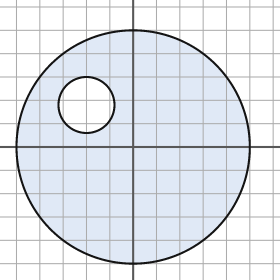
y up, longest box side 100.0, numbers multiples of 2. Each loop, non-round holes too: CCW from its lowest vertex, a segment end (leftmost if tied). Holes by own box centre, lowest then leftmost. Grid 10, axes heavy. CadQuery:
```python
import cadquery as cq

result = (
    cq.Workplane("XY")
    .moveTo(0.0, 0.0)
    .circle(50.0)
    .moveTo(-20.0, 18.0)
    .circle(12.0)
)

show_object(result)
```